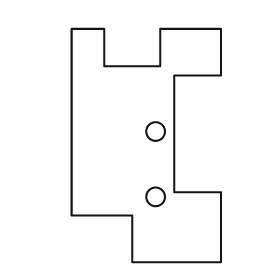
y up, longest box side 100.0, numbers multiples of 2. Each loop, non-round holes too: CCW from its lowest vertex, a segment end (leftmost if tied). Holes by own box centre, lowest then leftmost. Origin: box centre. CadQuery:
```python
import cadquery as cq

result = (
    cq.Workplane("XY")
    .moveTo(-6.0, -50.0)
    .lineTo(32.0, -50.0)
    .lineTo(32.0, -20.0)
    .lineTo(12.0, -20.0)
    .lineTo(12.0, 30.0)
    .lineTo(32.0, 30.0)
    .lineTo(32.0, 50.0)
    .lineTo(6.0, 50.0)
    .lineTo(6.0, 34.0)
    .lineTo(-18.0, 34.0)
    .lineTo(-18.0, 50.0)
    .lineTo(-32.0, 50.0)
    .lineTo(-32.0, -30.0)
    .lineTo(-6.0, -30.0)
    .close()
    .moveTo(4.0, -22.0)
    .circle(4.0)
    .moveTo(4.0, 6.0)
    .circle(4.0)
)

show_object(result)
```